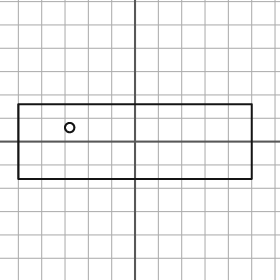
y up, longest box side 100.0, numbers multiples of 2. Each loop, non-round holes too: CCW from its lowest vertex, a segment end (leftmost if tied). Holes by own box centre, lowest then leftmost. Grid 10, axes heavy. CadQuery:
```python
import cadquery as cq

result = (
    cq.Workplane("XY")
    .moveTo(-50.0, -16.0)
    .lineTo(50.0, -16.0)
    .lineTo(50.0, 16.0)
    .lineTo(-50.0, 16.0)
    .close()
    .moveTo(-28.0, 6.0)
    .circle(2.0)
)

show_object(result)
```